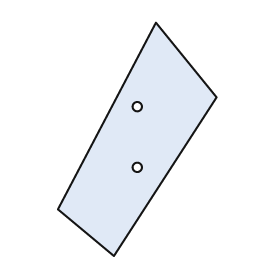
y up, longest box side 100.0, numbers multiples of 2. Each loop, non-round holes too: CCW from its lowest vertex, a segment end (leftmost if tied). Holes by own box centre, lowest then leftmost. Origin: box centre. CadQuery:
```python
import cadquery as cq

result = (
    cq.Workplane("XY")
    .moveTo(-10.0, -50.0)
    .lineTo(34.0, 18.0)
    .lineTo(8.0, 50.0)
    .lineTo(-34.0, -30.0)
    .close()
    .moveTo(0.0, -12.0)
    .circle(2.0)
    .moveTo(0.0, 14.0)
    .circle(2.0)
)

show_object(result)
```